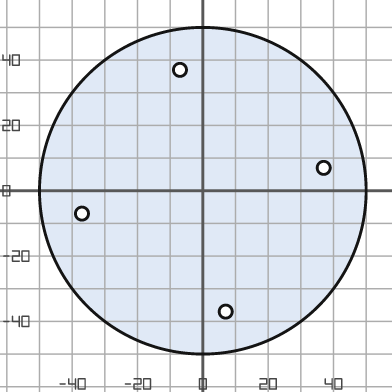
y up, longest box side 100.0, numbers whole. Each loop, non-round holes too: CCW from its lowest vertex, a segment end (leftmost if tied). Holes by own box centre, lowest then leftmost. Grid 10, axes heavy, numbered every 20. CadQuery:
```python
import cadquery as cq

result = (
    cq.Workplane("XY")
    .moveTo(0.0, 0.0)
    .circle(50.0)
    .moveTo(7.0, -37.0)
    .circle(2.0)
    .moveTo(-37.0, -7.0)
    .circle(2.0)
    .moveTo(37.0, 7.0)
    .circle(2.0)
    .moveTo(-7.0, 37.0)
    .circle(2.0)
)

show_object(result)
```